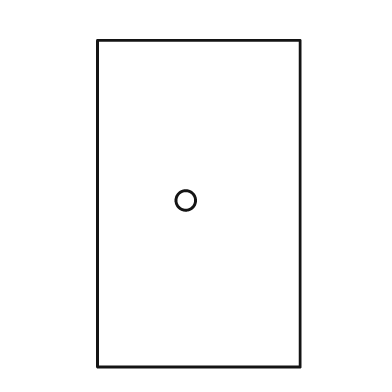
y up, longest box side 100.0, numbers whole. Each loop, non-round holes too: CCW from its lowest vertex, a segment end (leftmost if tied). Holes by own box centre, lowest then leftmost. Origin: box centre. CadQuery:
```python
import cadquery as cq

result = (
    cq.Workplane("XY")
    .moveTo(-31.0, -50.0)
    .lineTo(31.0, -50.0)
    .lineTo(31.0, 50.0)
    .lineTo(-31.0, 50.0)
    .close()
    .moveTo(-4.0, 1.0)
    .circle(3.0)
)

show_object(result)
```